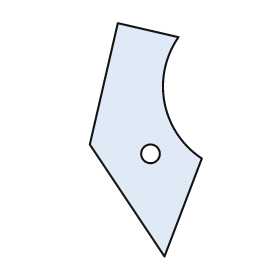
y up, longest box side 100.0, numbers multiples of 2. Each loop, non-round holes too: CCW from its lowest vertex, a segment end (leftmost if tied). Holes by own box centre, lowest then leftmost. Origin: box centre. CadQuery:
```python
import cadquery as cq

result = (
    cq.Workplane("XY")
    .moveTo(8.0, -50.0)
    .lineTo(24.0, -8.0)
    .threePointArc((8.0, 16.0), (14.0, 44.0))
    .lineTo(-12.0, 50.0)
    .lineTo(-24.0, -2.0)
    .close()
    .moveTo(2.0, -6.0)
    .circle(4.0)
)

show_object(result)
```